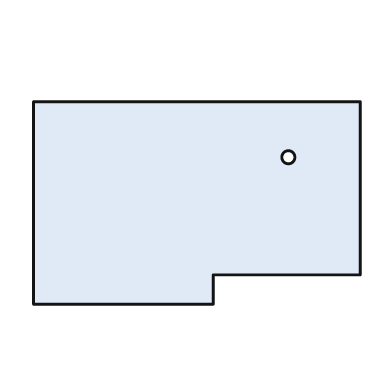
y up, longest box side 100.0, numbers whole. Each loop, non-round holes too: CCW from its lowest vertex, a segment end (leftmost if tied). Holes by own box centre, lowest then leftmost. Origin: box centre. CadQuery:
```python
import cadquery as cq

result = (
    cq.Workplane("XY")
    .moveTo(-50.0, -31.0)
    .lineTo(5.0, -31.0)
    .lineTo(5.0, -22.0)
    .lineTo(50.0, -22.0)
    .lineTo(50.0, 31.0)
    .lineTo(-50.0, 31.0)
    .close()
    .moveTo(28.0, 14.0)
    .circle(2.0)
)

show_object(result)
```